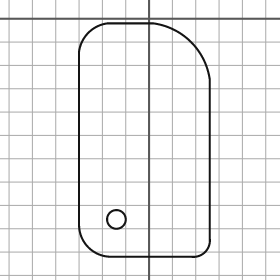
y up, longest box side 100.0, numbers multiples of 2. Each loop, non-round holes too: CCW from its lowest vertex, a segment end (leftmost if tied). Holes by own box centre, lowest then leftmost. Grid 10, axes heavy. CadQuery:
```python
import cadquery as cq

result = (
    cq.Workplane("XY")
    .moveTo(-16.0, -102.0)
    .lineTo(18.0, -102.0)
    .threePointArc((24.0, -100.0), (26.0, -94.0))
    .lineTo(26.0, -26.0)
    .threePointArc((18.0, -10.0), (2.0, -2.0))
    .lineTo(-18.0, -2.0)
    .threePointArc((-26.0, -6.0), (-30.0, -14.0))
    .lineTo(-30.0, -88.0)
    .threePointArc((-26.0, -98.0), (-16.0, -102.0))
    .close()
    .moveTo(-14.0, -86.0)
    .circle(4.0)
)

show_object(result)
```